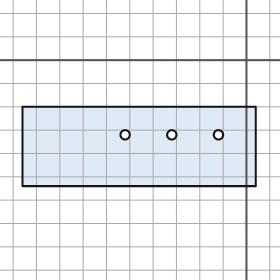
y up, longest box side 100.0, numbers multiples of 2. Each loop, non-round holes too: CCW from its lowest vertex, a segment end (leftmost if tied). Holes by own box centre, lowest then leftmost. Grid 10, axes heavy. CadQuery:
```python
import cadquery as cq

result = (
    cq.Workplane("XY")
    .moveTo(-96.0, -54.0)
    .lineTo(4.0, -54.0)
    .lineTo(4.0, -20.0)
    .lineTo(-96.0, -20.0)
    .close()
    .moveTo(-52.0, -32.0)
    .circle(2.0)
    .moveTo(-32.0, -32.0)
    .circle(2.0)
    .moveTo(-12.0, -32.0)
    .circle(2.0)
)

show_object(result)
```